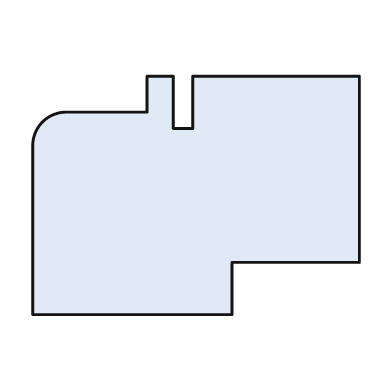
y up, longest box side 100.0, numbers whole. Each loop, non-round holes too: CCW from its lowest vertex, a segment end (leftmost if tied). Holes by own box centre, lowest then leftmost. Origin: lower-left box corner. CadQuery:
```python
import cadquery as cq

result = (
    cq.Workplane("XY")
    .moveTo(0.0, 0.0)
    .lineTo(61.0, 0.0)
    .lineTo(61.0, 16.0)
    .lineTo(100.0, 16.0)
    .lineTo(100.0, 73.0)
    .lineTo(49.0, 73.0)
    .lineTo(49.0, 57.0)
    .lineTo(43.0, 57.0)
    .lineTo(43.0, 73.0)
    .lineTo(35.0, 73.0)
    .lineTo(35.0, 62.0)
    .lineTo(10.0, 62.0)
    .threePointArc((3.0, 59.0), (0.0, 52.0))
    .close()
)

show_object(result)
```